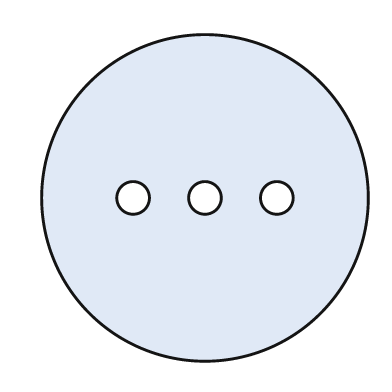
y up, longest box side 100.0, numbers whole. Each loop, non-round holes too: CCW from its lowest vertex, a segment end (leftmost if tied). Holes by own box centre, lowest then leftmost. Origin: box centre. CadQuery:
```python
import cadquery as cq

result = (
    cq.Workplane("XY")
    .moveTo(0.0, 0.0)
    .circle(50.0)
    .moveTo(-22.0, 0.0)
    .circle(5.0)
    .moveTo(0.0, 0.0)
    .circle(5.0)
    .moveTo(22.0, 0.0)
    .circle(5.0)
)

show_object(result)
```